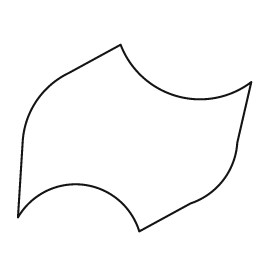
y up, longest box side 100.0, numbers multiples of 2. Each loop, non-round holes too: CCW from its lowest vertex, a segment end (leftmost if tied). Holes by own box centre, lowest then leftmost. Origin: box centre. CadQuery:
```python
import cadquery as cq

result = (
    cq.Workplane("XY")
    .moveTo(2.0, -40.0)
    .lineTo(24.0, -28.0)
    .threePointArc((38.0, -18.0), (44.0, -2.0))
    .lineTo(50.0, 24.0)
    .threePointArc((18.0, 18.0), (-6.0, 40.0))
    .lineTo(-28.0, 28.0)
    .threePointArc((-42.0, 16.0), (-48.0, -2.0))
    .lineTo(-50.0, -34.0)
    .threePointArc((-22.0, -20.0), (2.0, -40.0))
    .close()
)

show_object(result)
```